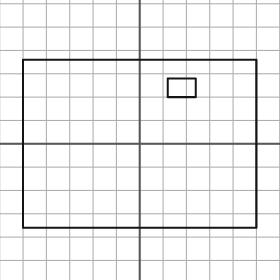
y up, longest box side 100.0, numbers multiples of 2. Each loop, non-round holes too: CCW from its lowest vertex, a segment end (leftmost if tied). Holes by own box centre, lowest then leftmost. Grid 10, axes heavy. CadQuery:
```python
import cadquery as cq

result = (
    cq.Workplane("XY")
    .moveTo(-50.0, -36.0)
    .lineTo(50.0, -36.0)
    .lineTo(50.0, 36.0)
    .lineTo(-50.0, 36.0)
    .close()
    .moveTo(12.0, 20.0)
    .lineTo(24.0, 20.0)
    .lineTo(24.0, 28.0)
    .lineTo(12.0, 28.0)
    .close()
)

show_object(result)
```